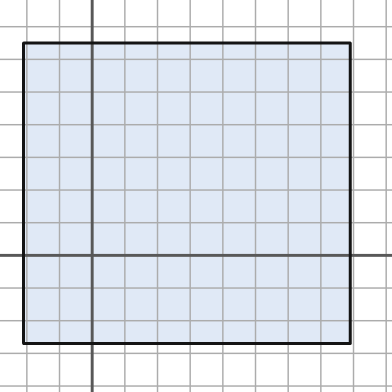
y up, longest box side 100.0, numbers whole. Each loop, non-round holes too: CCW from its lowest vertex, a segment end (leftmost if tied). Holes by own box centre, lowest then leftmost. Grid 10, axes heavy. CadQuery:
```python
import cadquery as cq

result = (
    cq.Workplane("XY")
    .moveTo(-21.0, -27.0)
    .lineTo(79.0, -27.0)
    .lineTo(79.0, 65.0)
    .lineTo(-21.0, 65.0)
    .close()
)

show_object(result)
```